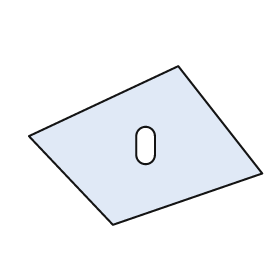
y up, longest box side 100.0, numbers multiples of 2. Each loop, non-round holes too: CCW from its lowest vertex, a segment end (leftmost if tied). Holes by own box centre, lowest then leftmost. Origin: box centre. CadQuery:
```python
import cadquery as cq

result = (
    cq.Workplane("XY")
    .moveTo(-14.0, -34.0)
    .lineTo(50.0, -12.0)
    .lineTo(14.0, 34.0)
    .lineTo(-50.0, 4.0)
    .close()
    .moveTo(-4.0, -4.0)
    .threePointArc((0.0, -8.0), (4.0, -4.0))
    .lineTo(4.0, 4.0)
    .threePointArc((0.0, 8.0), (-4.0, 4.0))
    .close()
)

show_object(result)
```